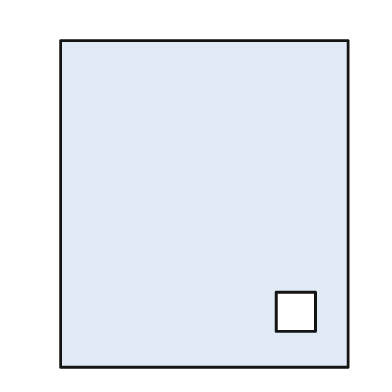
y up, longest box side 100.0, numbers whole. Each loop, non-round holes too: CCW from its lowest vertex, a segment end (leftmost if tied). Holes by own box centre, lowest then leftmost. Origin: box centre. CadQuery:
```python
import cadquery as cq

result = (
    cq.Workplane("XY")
    .moveTo(-44.0, -50.0)
    .lineTo(44.0, -50.0)
    .lineTo(44.0, 50.0)
    .lineTo(-44.0, 50.0)
    .close()
    .moveTo(22.0, -39.0)
    .lineTo(34.0, -39.0)
    .lineTo(34.0, -27.0)
    .lineTo(22.0, -27.0)
    .close()
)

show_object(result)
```